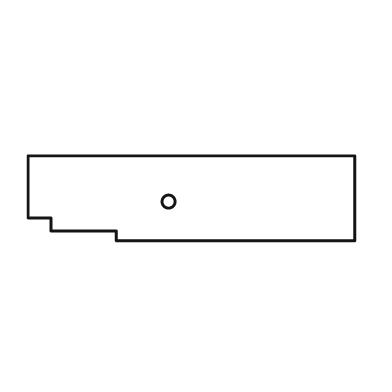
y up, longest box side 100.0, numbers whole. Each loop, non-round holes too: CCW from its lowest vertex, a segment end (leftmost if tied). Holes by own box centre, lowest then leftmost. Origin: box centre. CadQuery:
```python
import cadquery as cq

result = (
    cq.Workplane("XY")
    .moveTo(-23.0, -13.0)
    .lineTo(50.0, -13.0)
    .lineTo(50.0, 13.0)
    .lineTo(-50.0, 13.0)
    .lineTo(-50.0, -6.0)
    .lineTo(-43.0, -6.0)
    .lineTo(-43.0, -10.0)
    .lineTo(-23.0, -10.0)
    .close()
    .moveTo(-7.0, -1.0)
    .circle(2.0)
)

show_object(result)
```